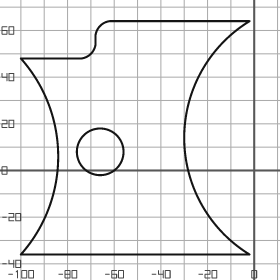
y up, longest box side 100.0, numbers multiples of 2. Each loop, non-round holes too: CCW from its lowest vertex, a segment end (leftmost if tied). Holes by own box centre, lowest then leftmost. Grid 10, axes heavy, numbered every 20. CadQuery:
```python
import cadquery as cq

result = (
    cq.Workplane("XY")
    .moveTo(-100.0, -36.0)
    .lineTo(-2.0, -36.0)
    .threePointArc((-30.0, 14.0), (-2.0, 64.0))
    .lineTo(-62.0, 64.0)
    .threePointArc((-66.0, 62.0), (-68.0, 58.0))
    .lineTo(-68.0, 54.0)
    .threePointArc((-70.0, 50.0), (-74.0, 48.0))
    .lineTo(-100.0, 48.0)
    .threePointArc((-84.0, 6.0), (-100.0, -36.0))
    .close()
    .moveTo(-66.0, 8.0)
    .circle(10.0)
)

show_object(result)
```